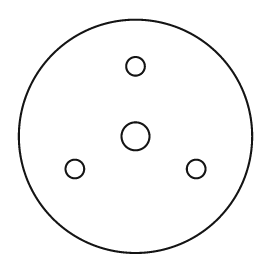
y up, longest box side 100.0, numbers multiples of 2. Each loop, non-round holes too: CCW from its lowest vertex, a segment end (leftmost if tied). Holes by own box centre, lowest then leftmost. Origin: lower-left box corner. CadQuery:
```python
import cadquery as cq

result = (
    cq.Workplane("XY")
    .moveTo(50.0, 50.0)
    .circle(50.0)
    .moveTo(24.0, 36.0)
    .circle(4.0)
    .moveTo(76.0, 36.0)
    .circle(4.0)
    .moveTo(50.0, 50.0)
    .circle(6.0)
    .moveTo(50.0, 80.0)
    .circle(4.0)
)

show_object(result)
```